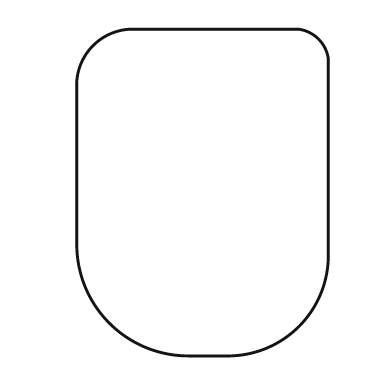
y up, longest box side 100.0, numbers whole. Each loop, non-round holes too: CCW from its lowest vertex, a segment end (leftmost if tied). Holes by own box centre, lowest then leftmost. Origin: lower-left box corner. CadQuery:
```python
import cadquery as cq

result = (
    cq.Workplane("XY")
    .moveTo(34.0, 0.0)
    .lineTo(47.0, 0.0)
    .threePointArc((68.0, 9.0), (77.0, 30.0))
    .lineTo(77.0, 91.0)
    .threePointArc((74.0, 97.0), (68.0, 100.0))
    .lineTo(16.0, 100.0)
    .threePointArc((5.0, 95.0), (0.0, 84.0))
    .lineTo(0.0, 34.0)
    .threePointArc((10.0, 10.0), (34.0, 0.0))
    .close()
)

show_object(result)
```